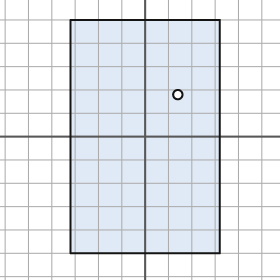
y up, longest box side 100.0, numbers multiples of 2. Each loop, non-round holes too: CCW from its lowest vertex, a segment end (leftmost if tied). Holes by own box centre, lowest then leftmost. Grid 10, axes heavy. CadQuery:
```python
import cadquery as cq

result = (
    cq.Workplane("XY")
    .moveTo(-32.0, -50.0)
    .lineTo(32.0, -50.0)
    .lineTo(32.0, 50.0)
    .lineTo(-32.0, 50.0)
    .close()
    .moveTo(14.0, 18.0)
    .circle(2.0)
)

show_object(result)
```